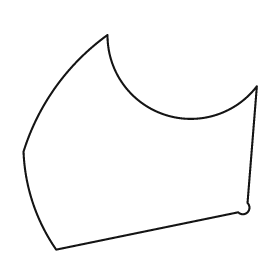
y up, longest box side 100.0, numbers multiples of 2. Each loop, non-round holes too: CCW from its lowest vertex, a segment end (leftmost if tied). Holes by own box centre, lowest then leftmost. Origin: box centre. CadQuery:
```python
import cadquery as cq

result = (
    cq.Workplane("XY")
    .moveTo(-36.0, -46.0)
    .lineTo(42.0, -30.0)
    .threePointArc((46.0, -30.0), (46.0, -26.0))
    .lineTo(50.0, 24.0)
    .threePointArc((10.0, 12.0), (-14.0, 46.0))
    .threePointArc((-36.0, 24.0), (-50.0, -4.0))
    .threePointArc((-46.0, -26.0), (-36.0, -46.0))
    .close()
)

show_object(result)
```